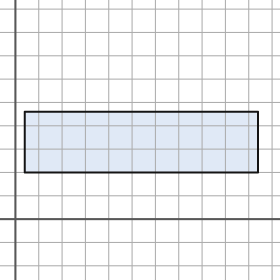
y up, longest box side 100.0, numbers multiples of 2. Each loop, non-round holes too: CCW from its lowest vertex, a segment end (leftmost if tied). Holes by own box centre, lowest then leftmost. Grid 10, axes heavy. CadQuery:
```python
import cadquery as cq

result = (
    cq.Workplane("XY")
    .moveTo(4.0, 20.0)
    .lineTo(104.0, 20.0)
    .lineTo(104.0, 46.0)
    .lineTo(4.0, 46.0)
    .close()
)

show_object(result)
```